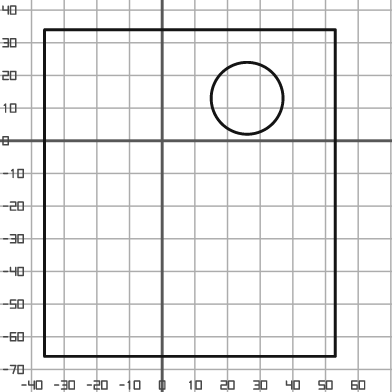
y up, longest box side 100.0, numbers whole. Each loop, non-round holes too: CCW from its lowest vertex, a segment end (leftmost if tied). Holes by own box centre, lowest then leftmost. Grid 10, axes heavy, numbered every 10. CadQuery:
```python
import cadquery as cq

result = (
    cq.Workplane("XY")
    .moveTo(-36.0, -66.0)
    .lineTo(53.0, -66.0)
    .lineTo(53.0, 34.0)
    .lineTo(-36.0, 34.0)
    .close()
    .moveTo(26.0, 13.0)
    .circle(11.0)
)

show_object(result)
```